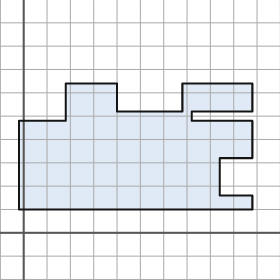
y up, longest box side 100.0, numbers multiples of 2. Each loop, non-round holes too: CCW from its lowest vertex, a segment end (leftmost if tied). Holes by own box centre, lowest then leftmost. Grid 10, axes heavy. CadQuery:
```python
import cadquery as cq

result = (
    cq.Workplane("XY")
    .moveTo(-2.0, 10.0)
    .lineTo(98.0, 10.0)
    .lineTo(98.0, 16.0)
    .lineTo(84.0, 16.0)
    .lineTo(84.0, 32.0)
    .lineTo(98.0, 32.0)
    .lineTo(98.0, 48.0)
    .lineTo(72.0, 48.0)
    .lineTo(72.0, 52.0)
    .lineTo(98.0, 52.0)
    .lineTo(98.0, 64.0)
    .lineTo(68.0, 64.0)
    .lineTo(68.0, 52.0)
    .lineTo(40.0, 52.0)
    .lineTo(40.0, 64.0)
    .lineTo(18.0, 64.0)
    .lineTo(18.0, 48.0)
    .lineTo(-2.0, 48.0)
    .close()
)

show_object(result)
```